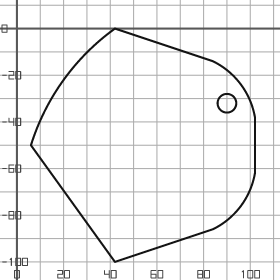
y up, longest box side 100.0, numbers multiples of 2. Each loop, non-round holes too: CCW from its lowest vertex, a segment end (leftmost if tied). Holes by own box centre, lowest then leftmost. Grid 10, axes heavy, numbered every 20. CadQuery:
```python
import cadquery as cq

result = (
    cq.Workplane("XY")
    .moveTo(42.0, -100.0)
    .lineTo(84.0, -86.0)
    .threePointArc((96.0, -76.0), (102.0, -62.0))
    .lineTo(102.0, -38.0)
    .threePointArc((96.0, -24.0), (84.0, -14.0))
    .lineTo(42.0, 0.0)
    .threePointArc((20.0, -22.0), (6.0, -50.0))
    .close()
    .moveTo(90.0, -32.0)
    .circle(4.0)
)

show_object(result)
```